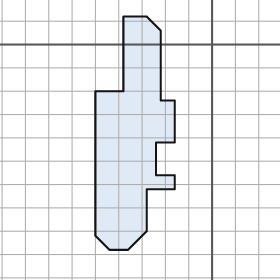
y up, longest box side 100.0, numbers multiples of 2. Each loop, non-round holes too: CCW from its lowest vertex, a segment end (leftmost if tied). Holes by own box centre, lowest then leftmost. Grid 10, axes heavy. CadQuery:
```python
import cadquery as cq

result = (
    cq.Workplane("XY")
    .moveTo(-44.0, -88.0)
    .lineTo(-36.0, -88.0)
    .lineTo(-28.0, -80.0)
    .lineTo(-28.0, -62.0)
    .lineTo(-16.0, -62.0)
    .lineTo(-16.0, -56.0)
    .lineTo(-24.0, -56.0)
    .lineTo(-24.0, -42.0)
    .lineTo(-16.0, -42.0)
    .lineTo(-16.0, -24.0)
    .lineTo(-22.0, -24.0)
    .lineTo(-22.0, 6.0)
    .lineTo(-28.0, 12.0)
    .lineTo(-38.0, 12.0)
    .lineTo(-38.0, -20.0)
    .lineTo(-50.0, -20.0)
    .lineTo(-50.0, -82.0)
    .close()
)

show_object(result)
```